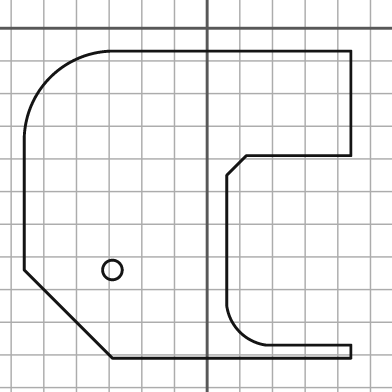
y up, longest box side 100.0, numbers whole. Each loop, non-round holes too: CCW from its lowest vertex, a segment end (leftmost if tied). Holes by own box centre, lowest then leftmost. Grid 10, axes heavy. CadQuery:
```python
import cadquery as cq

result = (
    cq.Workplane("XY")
    .moveTo(-29.0, -101.0)
    .lineTo(44.0, -101.0)
    .lineTo(44.0, -97.0)
    .lineTo(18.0, -97.0)
    .threePointArc((10.0, -93.0), (6.0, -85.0))
    .lineTo(6.0, -45.0)
    .lineTo(12.0, -39.0)
    .lineTo(44.0, -39.0)
    .lineTo(44.0, -7.0)
    .lineTo(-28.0, -7.0)
    .threePointArc((-48.0, -15.0), (-56.0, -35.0))
    .lineTo(-56.0, -74.0)
    .close()
    .moveTo(-29.0, -74.0)
    .circle(3.0)
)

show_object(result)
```